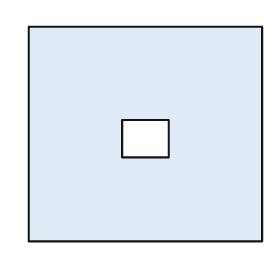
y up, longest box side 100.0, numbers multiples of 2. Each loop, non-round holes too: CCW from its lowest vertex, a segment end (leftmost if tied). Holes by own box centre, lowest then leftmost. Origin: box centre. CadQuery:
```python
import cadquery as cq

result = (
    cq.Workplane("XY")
    .moveTo(-50.0, -46.0)
    .lineTo(50.0, -46.0)
    .lineTo(50.0, 46.0)
    .lineTo(-50.0, 46.0)
    .close()
    .moveTo(-10.0, -10.0)
    .lineTo(10.0, -10.0)
    .lineTo(10.0, 6.0)
    .lineTo(-10.0, 6.0)
    .close()
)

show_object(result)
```